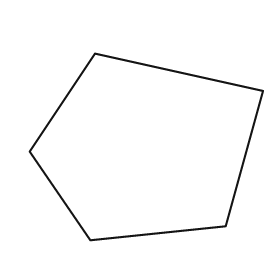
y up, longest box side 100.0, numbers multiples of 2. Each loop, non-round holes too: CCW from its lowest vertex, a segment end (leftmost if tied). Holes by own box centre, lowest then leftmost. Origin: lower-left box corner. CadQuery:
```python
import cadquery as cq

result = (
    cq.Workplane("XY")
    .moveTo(26.0, 0.0)
    .lineTo(84.0, 6.0)
    .lineTo(100.0, 64.0)
    .lineTo(28.0, 80.0)
    .lineTo(0.0, 38.0)
    .close()
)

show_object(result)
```